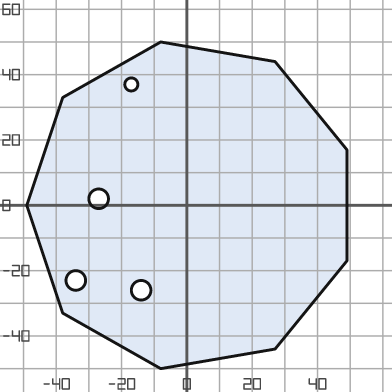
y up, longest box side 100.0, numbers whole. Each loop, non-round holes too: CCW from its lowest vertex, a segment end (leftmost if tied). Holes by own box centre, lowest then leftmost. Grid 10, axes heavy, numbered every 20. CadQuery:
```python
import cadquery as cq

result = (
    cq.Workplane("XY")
    .moveTo(-8.0, -50.0)
    .lineTo(27.0, -44.0)
    .lineTo(49.0, -17.0)
    .lineTo(49.0, 17.0)
    .lineTo(27.0, 44.0)
    .lineTo(-8.0, 50.0)
    .lineTo(-38.0, 33.0)
    .lineTo(-49.0, 0.0)
    .lineTo(-38.0, -33.0)
    .close()
    .moveTo(-14.0, -26.0)
    .circle(3.0)
    .moveTo(-34.0, -23.0)
    .circle(3.0)
    .moveTo(-27.0, 2.0)
    .circle(3.0)
    .moveTo(-17.0, 37.0)
    .circle(2.0)
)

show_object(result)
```